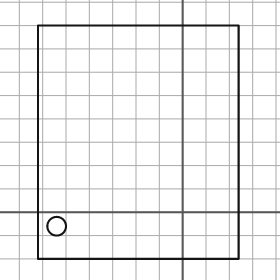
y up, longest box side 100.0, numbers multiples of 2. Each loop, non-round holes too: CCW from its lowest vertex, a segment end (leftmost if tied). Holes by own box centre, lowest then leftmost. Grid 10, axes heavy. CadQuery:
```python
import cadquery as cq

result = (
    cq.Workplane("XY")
    .moveTo(-62.0, -20.0)
    .lineTo(24.0, -20.0)
    .lineTo(24.0, 80.0)
    .lineTo(-62.0, 80.0)
    .close()
    .moveTo(-54.0, -6.0)
    .circle(4.0)
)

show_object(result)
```